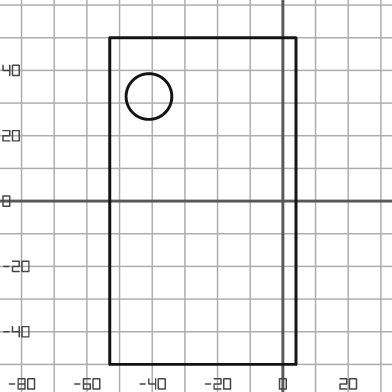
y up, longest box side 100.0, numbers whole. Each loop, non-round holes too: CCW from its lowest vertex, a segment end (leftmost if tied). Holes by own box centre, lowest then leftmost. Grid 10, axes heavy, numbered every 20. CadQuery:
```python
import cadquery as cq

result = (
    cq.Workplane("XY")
    .moveTo(-53.0, -50.0)
    .lineTo(4.0, -50.0)
    .lineTo(4.0, 50.0)
    .lineTo(-53.0, 50.0)
    .close()
    .moveTo(-41.0, 32.0)
    .circle(7.0)
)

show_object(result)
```